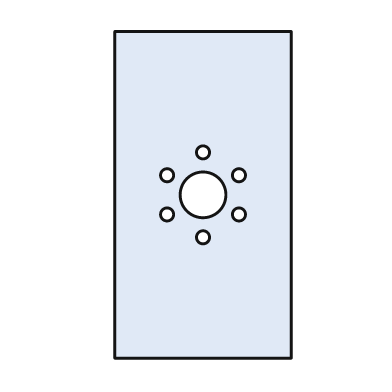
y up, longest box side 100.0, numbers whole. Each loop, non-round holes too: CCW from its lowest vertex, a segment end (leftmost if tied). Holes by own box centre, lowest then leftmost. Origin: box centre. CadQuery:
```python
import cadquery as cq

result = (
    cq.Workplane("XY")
    .moveTo(-27.0, -50.0)
    .lineTo(27.0, -50.0)
    .lineTo(27.0, 50.0)
    .lineTo(-27.0, 50.0)
    .close()
    .moveTo(0.0, -13.0)
    .circle(2.0)
    .moveTo(-11.0, -6.0)
    .circle(2.0)
    .moveTo(11.0, -6.0)
    .circle(2.0)
    .moveTo(0.0, 0.0)
    .circle(7.0)
    .moveTo(-11.0, 6.0)
    .circle(2.0)
    .moveTo(11.0, 6.0)
    .circle(2.0)
    .moveTo(0.0, 13.0)
    .circle(2.0)
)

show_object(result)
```